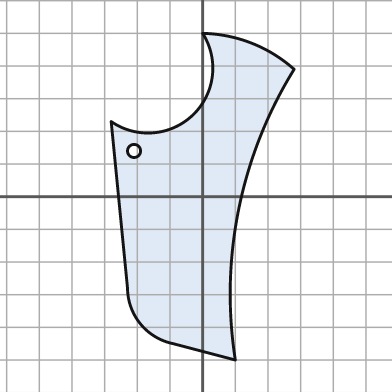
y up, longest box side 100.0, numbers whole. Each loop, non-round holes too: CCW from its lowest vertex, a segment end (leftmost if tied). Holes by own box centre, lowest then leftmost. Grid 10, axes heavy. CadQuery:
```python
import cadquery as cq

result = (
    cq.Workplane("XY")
    .moveTo(10.0, -50.0)
    .threePointArc((11.0, -4.0), (28.0, 39.0))
    .threePointArc((15.0, 47.0), (0.0, 50.0))
    .threePointArc((-3.0, 25.0), (-28.0, 23.0))
    .lineTo(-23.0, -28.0)
    .threePointArc((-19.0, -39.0), (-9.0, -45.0))
    .close()
    .moveTo(-21.0, 14.0)
    .circle(2.0)
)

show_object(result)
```